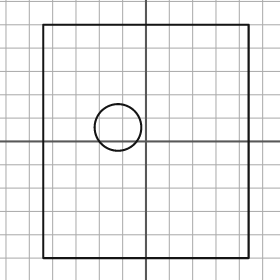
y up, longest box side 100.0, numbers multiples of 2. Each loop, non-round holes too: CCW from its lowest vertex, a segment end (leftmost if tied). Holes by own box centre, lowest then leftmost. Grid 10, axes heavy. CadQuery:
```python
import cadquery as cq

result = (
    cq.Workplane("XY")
    .moveTo(-44.0, -50.0)
    .lineTo(44.0, -50.0)
    .lineTo(44.0, 50.0)
    .lineTo(-44.0, 50.0)
    .close()
    .moveTo(-12.0, 6.0)
    .circle(10.0)
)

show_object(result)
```